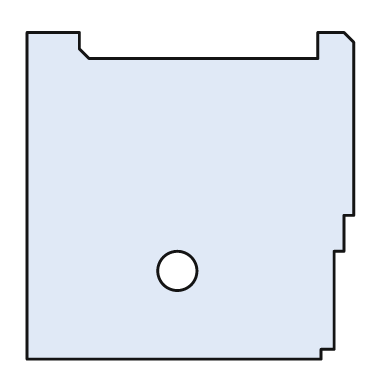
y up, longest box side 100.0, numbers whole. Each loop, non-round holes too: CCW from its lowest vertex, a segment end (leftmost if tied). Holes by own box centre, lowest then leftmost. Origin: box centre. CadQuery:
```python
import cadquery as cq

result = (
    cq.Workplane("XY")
    .moveTo(-50.0, -50.0)
    .lineTo(40.0, -50.0)
    .lineTo(40.0, -47.0)
    .lineTo(44.0, -47.0)
    .lineTo(44.0, -17.0)
    .lineTo(47.0, -17.0)
    .lineTo(47.0, -6.0)
    .lineTo(50.0, -6.0)
    .lineTo(50.0, 47.0)
    .lineTo(47.0, 50.0)
    .lineTo(39.0, 50.0)
    .lineTo(39.0, 42.0)
    .lineTo(-31.0, 42.0)
    .lineTo(-34.0, 45.0)
    .lineTo(-34.0, 50.0)
    .lineTo(-50.0, 50.0)
    .close()
    .moveTo(-4.0, -23.0)
    .circle(6.0)
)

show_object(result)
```